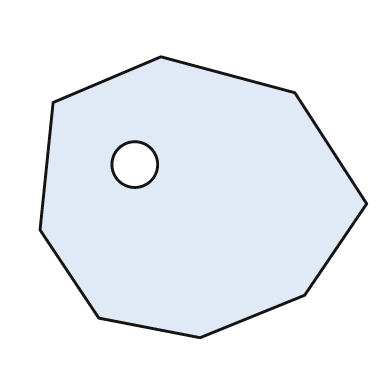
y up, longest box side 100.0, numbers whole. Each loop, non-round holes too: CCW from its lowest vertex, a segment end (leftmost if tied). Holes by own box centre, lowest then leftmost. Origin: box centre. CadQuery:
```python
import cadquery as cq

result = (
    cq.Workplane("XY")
    .moveTo(-1.0, -43.0)
    .lineTo(31.0, -30.0)
    .lineTo(50.0, -2.0)
    .lineTo(28.0, 32.0)
    .lineTo(-13.0, 43.0)
    .lineTo(-46.0, 29.0)
    .lineTo(-50.0, -10.0)
    .lineTo(-32.0, -37.0)
    .close()
    .moveTo(-21.0, 10.0)
    .circle(7.0)
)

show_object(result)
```